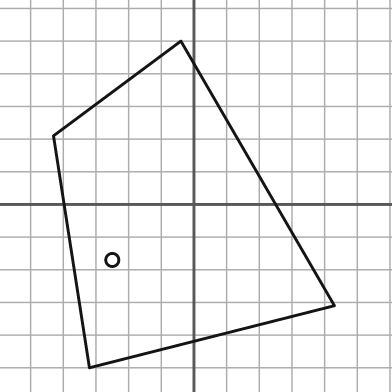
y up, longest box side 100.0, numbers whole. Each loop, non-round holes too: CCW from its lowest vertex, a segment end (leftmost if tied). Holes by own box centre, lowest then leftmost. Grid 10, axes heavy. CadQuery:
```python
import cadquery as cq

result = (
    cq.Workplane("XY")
    .moveTo(-32.0, -50.0)
    .lineTo(43.0, -31.0)
    .lineTo(-4.0, 50.0)
    .lineTo(-43.0, 21.0)
    .close()
    .moveTo(-25.0, -17.0)
    .circle(2.0)
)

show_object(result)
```